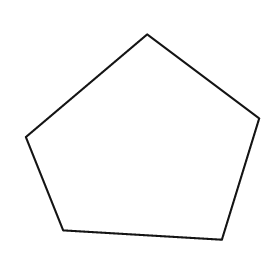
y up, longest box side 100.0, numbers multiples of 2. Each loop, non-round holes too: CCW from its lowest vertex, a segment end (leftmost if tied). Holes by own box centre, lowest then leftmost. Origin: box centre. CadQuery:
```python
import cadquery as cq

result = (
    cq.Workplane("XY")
    .moveTo(34.0, -44.0)
    .lineTo(50.0, 8.0)
    .lineTo(2.0, 44.0)
    .lineTo(-50.0, 0.0)
    .lineTo(-34.0, -40.0)
    .close()
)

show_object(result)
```